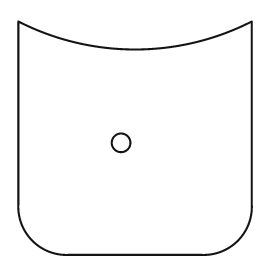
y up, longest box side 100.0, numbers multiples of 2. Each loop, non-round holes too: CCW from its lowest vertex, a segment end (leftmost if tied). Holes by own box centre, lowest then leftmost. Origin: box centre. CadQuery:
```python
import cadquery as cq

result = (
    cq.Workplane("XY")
    .moveTo(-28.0, -50.0)
    .lineTo(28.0, -50.0)
    .threePointArc((44.0, -44.0), (50.0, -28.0))
    .lineTo(50.0, 50.0)
    .threePointArc((0.0, 38.0), (-50.0, 50.0))
    .lineTo(-50.0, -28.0)
    .threePointArc((-44.0, -44.0), (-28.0, -50.0))
    .close()
    .moveTo(-6.0, -2.0)
    .circle(4.0)
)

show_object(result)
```